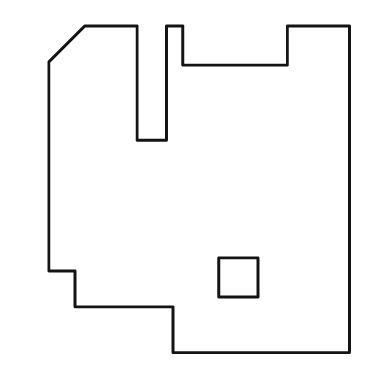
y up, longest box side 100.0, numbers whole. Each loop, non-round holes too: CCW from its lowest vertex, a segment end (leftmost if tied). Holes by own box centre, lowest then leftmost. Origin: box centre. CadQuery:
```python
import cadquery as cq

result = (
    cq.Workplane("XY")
    .moveTo(-8.0, -50.0)
    .lineTo(46.0, -50.0)
    .lineTo(46.0, 50.0)
    .lineTo(27.0, 50.0)
    .lineTo(27.0, 38.0)
    .lineTo(-5.0, 38.0)
    .lineTo(-5.0, 50.0)
    .lineTo(-10.0, 50.0)
    .lineTo(-10.0, 15.0)
    .lineTo(-19.0, 15.0)
    .lineTo(-19.0, 50.0)
    .lineTo(-35.0, 50.0)
    .lineTo(-46.0, 39.0)
    .lineTo(-46.0, -25.0)
    .lineTo(-38.0, -25.0)
    .lineTo(-38.0, -36.0)
    .lineTo(-8.0, -36.0)
    .close()
    .moveTo(6.0, -33.0)
    .lineTo(18.0, -33.0)
    .lineTo(18.0, -21.0)
    .lineTo(6.0, -21.0)
    .close()
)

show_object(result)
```